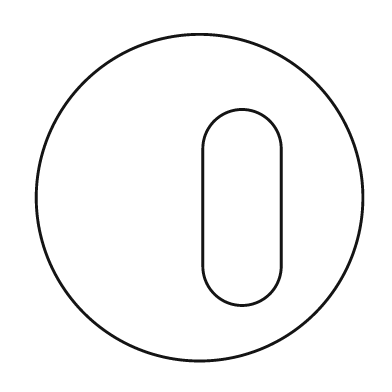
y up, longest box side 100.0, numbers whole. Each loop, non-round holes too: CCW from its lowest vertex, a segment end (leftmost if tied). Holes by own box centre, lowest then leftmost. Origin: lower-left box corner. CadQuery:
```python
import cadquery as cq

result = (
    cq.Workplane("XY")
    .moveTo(50.0, 50.0)
    .circle(50.0)
    .moveTo(51.0, 29.0)
    .threePointArc((63.0, 17.0), (75.0, 29.0))
    .lineTo(75.0, 65.0)
    .threePointArc((63.0, 77.0), (51.0, 65.0))
    .close()
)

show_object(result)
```